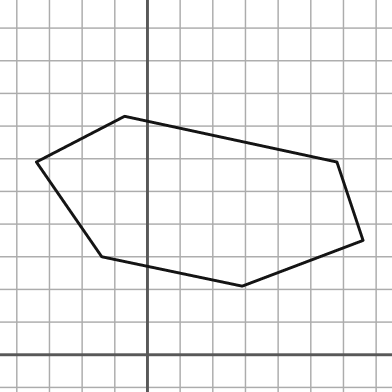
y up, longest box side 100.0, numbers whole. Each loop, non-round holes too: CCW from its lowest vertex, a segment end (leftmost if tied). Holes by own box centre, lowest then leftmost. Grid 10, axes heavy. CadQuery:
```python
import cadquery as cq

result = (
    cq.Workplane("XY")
    .moveTo(29.0, 21.0)
    .lineTo(66.0, 35.0)
    .lineTo(58.0, 59.0)
    .lineTo(-7.0, 73.0)
    .lineTo(-34.0, 59.0)
    .lineTo(-14.0, 30.0)
    .close()
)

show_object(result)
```